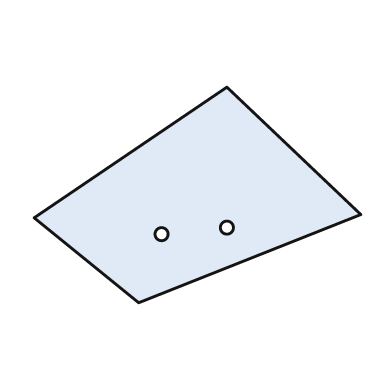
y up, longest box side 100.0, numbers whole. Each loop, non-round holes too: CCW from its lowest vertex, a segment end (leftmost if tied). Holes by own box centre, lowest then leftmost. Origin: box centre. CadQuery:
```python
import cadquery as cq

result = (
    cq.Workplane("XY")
    .moveTo(-18.0, -33.0)
    .lineTo(50.0, -6.0)
    .lineTo(9.0, 33.0)
    .lineTo(-50.0, -7.0)
    .close()
    .moveTo(-11.0, -12.0)
    .circle(2.0)
    .moveTo(9.0, -10.0)
    .circle(2.0)
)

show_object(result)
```